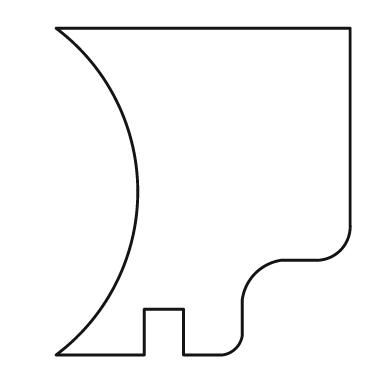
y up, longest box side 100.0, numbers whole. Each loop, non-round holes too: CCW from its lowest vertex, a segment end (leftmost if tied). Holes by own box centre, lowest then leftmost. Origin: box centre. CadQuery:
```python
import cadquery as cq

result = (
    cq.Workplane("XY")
    .moveTo(-45.0, -50.0)
    .lineTo(-18.0, -50.0)
    .lineTo(-18.0, -36.0)
    .lineTo(-6.0, -36.0)
    .lineTo(-6.0, -50.0)
    .lineTo(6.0, -50.0)
    .threePointArc((10.0, -48.0), (12.0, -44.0))
    .lineTo(12.0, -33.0)
    .threePointArc((16.0, -25.0), (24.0, -21.0))
    .lineTo(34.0, -21.0)
    .threePointArc((42.0, -18.0), (45.0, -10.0))
    .lineTo(45.0, 50.0)
    .lineTo(-45.0, 50.0)
    .threePointArc((-20.0, 0.0), (-45.0, -50.0))
    .close()
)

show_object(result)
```